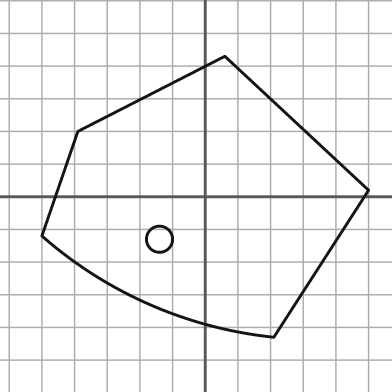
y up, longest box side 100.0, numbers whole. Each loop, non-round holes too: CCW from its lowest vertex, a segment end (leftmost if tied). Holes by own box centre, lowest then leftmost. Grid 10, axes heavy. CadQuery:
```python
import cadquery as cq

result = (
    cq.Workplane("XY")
    .moveTo(21.0, -43.0)
    .lineTo(50.0, 2.0)
    .lineTo(6.0, 43.0)
    .lineTo(-39.0, 20.0)
    .lineTo(-50.0, -12.0)
    .threePointArc((-17.0, -33.0), (21.0, -43.0))
    .close()
    .moveTo(-14.0, -13.0)
    .circle(4.0)
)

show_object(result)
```